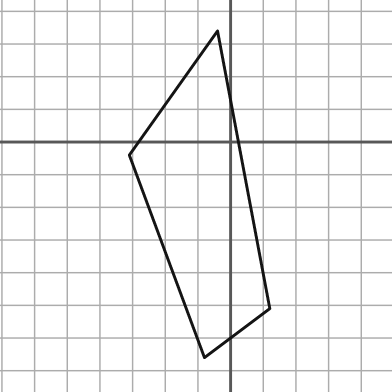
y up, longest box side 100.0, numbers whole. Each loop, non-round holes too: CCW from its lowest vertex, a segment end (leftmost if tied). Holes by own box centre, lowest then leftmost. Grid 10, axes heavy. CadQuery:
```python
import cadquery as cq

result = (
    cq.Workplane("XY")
    .moveTo(-8.0, -66.0)
    .lineTo(12.0, -51.0)
    .lineTo(-4.0, 34.0)
    .lineTo(-31.0, -4.0)
    .close()
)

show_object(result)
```